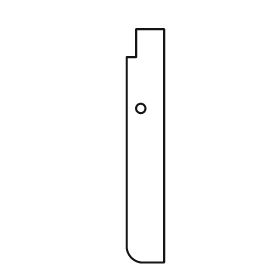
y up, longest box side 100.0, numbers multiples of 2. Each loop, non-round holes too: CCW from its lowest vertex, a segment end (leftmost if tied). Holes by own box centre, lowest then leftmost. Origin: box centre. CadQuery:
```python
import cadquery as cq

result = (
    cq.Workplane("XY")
    .moveTo(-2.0, -50.0)
    .lineTo(8.0, -50.0)
    .lineTo(8.0, 50.0)
    .lineTo(-4.0, 50.0)
    .lineTo(-4.0, 38.0)
    .lineTo(-8.0, 38.0)
    .lineTo(-8.0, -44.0)
    .threePointArc((-6.0, -48.0), (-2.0, -50.0))
    .close()
    .moveTo(-2.0, 16.0)
    .circle(2.0)
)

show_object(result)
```